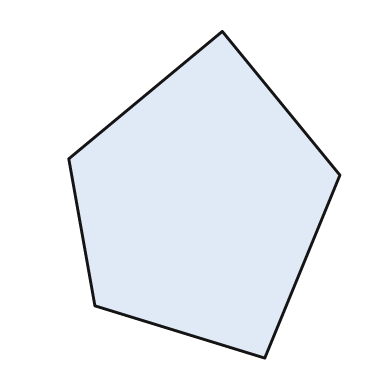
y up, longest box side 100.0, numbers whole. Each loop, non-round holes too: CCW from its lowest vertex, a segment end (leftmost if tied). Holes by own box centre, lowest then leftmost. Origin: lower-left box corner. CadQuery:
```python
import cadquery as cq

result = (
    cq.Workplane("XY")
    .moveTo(60.0, 0.0)
    .lineTo(83.0, 56.0)
    .lineTo(47.0, 100.0)
    .lineTo(0.0, 61.0)
    .lineTo(8.0, 16.0)
    .close()
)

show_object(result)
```